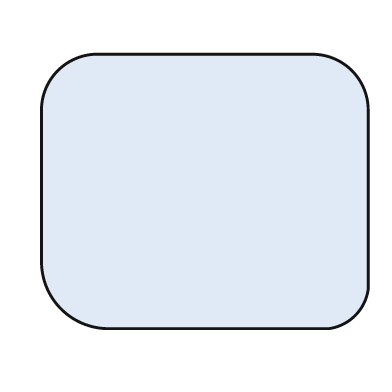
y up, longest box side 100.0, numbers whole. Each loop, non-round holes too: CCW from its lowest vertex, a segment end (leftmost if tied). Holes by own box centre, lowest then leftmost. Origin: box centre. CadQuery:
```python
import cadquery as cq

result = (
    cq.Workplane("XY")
    .moveTo(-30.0, -42.0)
    .lineTo(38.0, -42.0)
    .threePointArc((46.0, -38.0), (50.0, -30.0))
    .lineTo(50.0, 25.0)
    .threePointArc((45.0, 37.0), (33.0, 42.0))
    .lineTo(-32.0, 42.0)
    .threePointArc((-45.0, 37.0), (-50.0, 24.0))
    .lineTo(-50.0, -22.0)
    .threePointArc((-44.0, -36.0), (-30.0, -42.0))
    .close()
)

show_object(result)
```